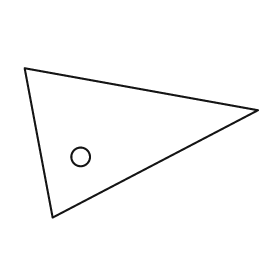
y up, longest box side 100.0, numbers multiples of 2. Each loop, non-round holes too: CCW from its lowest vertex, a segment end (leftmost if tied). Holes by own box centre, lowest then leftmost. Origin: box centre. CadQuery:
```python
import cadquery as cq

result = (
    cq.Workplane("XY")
    .moveTo(-38.0, -32.0)
    .lineTo(50.0, 14.0)
    .lineTo(-50.0, 32.0)
    .close()
    .moveTo(-26.0, -6.0)
    .circle(4.0)
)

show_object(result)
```